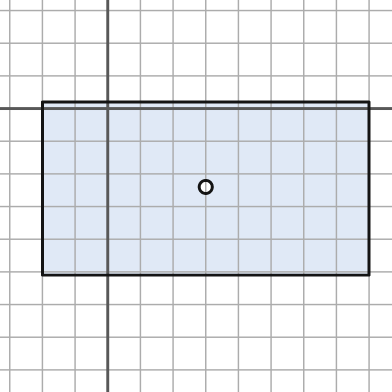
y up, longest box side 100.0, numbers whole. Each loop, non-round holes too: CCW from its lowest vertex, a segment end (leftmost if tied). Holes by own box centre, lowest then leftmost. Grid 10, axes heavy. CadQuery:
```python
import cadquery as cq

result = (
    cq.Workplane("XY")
    .moveTo(-20.0, -51.0)
    .lineTo(80.0, -51.0)
    .lineTo(80.0, 2.0)
    .lineTo(-20.0, 2.0)
    .close()
    .moveTo(30.0, -24.0)
    .circle(2.0)
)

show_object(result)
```